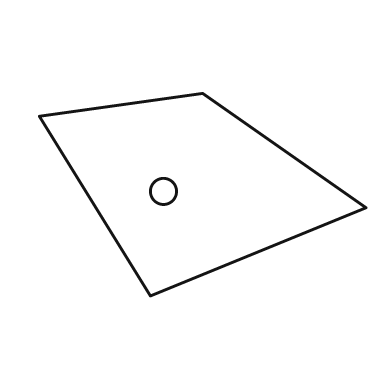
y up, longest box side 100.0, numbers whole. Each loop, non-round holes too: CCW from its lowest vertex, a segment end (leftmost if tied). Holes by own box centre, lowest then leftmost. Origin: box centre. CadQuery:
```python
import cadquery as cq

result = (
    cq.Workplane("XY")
    .moveTo(-16.0, -31.0)
    .lineTo(50.0, -4.0)
    .lineTo(0.0, 31.0)
    .lineTo(-50.0, 24.0)
    .close()
    .moveTo(-12.0, 1.0)
    .circle(4.0)
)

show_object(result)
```